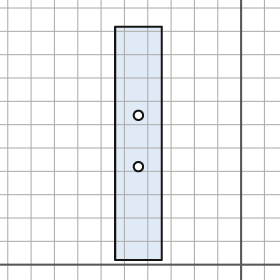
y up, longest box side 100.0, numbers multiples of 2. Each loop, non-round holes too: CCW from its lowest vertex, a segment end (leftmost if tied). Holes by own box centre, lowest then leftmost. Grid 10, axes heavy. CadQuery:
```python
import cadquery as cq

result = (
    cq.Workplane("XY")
    .moveTo(-54.0, 2.0)
    .lineTo(-34.0, 2.0)
    .lineTo(-34.0, 102.0)
    .lineTo(-54.0, 102.0)
    .close()
    .moveTo(-44.0, 42.0)
    .circle(2.0)
    .moveTo(-44.0, 64.0)
    .circle(2.0)
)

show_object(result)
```